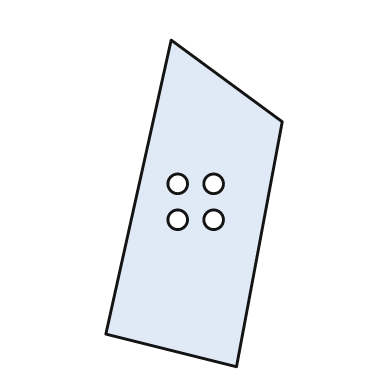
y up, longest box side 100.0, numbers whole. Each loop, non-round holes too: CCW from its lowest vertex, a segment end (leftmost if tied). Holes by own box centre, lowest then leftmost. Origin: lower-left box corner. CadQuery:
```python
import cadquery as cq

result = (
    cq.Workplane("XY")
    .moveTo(40.0, 0.0)
    .lineTo(54.0, 75.0)
    .lineTo(20.0, 100.0)
    .lineTo(0.0, 10.0)
    .close()
    .moveTo(22.0, 45.0)
    .circle(3.0)
    .moveTo(33.0, 45.0)
    .circle(3.0)
    .moveTo(22.0, 56.0)
    .circle(3.0)
    .moveTo(33.0, 56.0)
    .circle(3.0)
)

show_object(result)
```